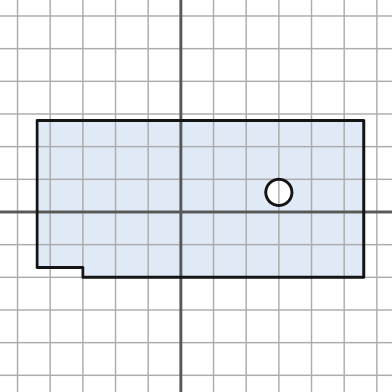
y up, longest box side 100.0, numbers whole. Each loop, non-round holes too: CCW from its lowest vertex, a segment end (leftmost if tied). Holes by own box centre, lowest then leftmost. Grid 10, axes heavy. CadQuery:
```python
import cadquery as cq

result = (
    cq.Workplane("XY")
    .moveTo(-30.0, -20.0)
    .lineTo(56.0, -20.0)
    .lineTo(56.0, 28.0)
    .lineTo(-44.0, 28.0)
    .lineTo(-44.0, -17.0)
    .lineTo(-30.0, -17.0)
    .close()
    .moveTo(30.0, 6.0)
    .circle(4.0)
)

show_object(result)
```